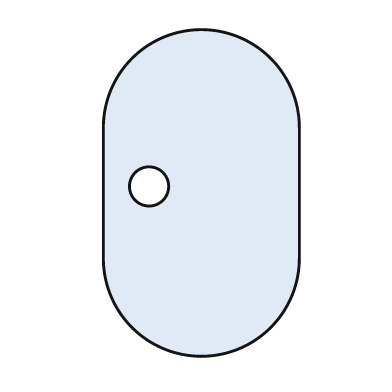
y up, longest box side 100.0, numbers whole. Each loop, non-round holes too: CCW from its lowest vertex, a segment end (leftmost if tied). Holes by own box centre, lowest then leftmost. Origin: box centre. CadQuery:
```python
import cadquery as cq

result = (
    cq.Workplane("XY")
    .moveTo(-30.0, -20.0)
    .threePointArc((0.0, -50.0), (30.0, -20.0))
    .lineTo(30.0, 20.0)
    .threePointArc((0.0, 50.0), (-30.0, 20.0))
    .close()
    .moveTo(-16.0, 2.0)
    .circle(6.0)
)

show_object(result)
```